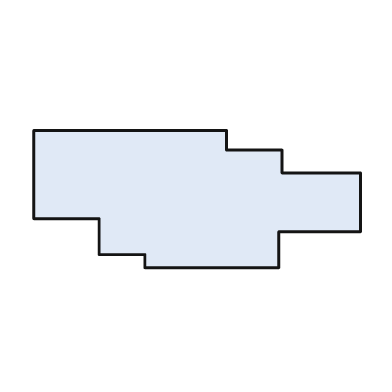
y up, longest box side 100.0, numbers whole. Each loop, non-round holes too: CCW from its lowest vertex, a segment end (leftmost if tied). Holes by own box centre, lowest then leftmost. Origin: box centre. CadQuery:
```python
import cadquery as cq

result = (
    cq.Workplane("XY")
    .moveTo(-16.0, -21.0)
    .lineTo(25.0, -21.0)
    .lineTo(25.0, -10.0)
    .lineTo(50.0, -10.0)
    .lineTo(50.0, 8.0)
    .lineTo(26.0, 8.0)
    .lineTo(26.0, 15.0)
    .lineTo(9.0, 15.0)
    .lineTo(9.0, 21.0)
    .lineTo(-50.0, 21.0)
    .lineTo(-50.0, -6.0)
    .lineTo(-30.0, -6.0)
    .lineTo(-30.0, -17.0)
    .lineTo(-16.0, -17.0)
    .close()
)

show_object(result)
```